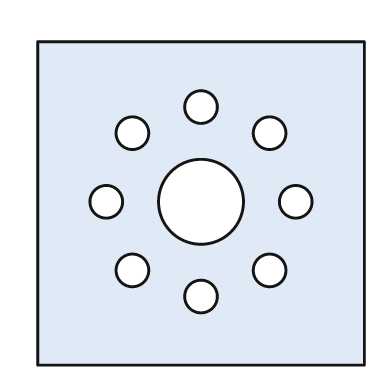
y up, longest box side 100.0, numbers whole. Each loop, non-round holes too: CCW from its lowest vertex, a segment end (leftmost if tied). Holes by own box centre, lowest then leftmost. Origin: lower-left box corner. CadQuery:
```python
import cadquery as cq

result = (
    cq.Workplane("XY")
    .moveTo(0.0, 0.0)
    .lineTo(100.0, 0.0)
    .lineTo(100.0, 99.0)
    .lineTo(0.0, 99.0)
    .close()
    .moveTo(50.0, 21.0)
    .circle(5.0)
    .moveTo(29.0, 29.0)
    .circle(5.0)
    .moveTo(71.0, 29.0)
    .circle(5.0)
    .moveTo(21.0, 50.0)
    .circle(5.0)
    .moveTo(50.0, 50.0)
    .circle(13.0)
    .moveTo(79.0, 50.0)
    .circle(5.0)
    .moveTo(29.0, 71.0)
    .circle(5.0)
    .moveTo(71.0, 71.0)
    .circle(5.0)
    .moveTo(50.0, 79.0)
    .circle(5.0)
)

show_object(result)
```